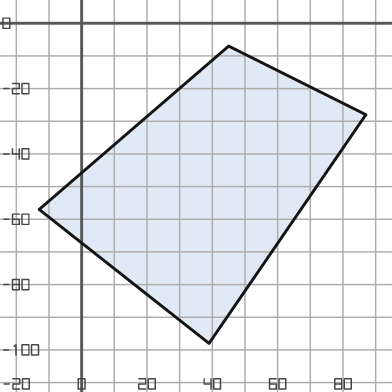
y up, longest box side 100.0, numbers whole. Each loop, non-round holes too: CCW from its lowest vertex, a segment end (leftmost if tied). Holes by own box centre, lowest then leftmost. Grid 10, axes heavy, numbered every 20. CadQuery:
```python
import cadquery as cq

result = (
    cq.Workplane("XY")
    .moveTo(39.0, -98.0)
    .lineTo(87.0, -28.0)
    .lineTo(45.0, -7.0)
    .lineTo(-13.0, -57.0)
    .close()
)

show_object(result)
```